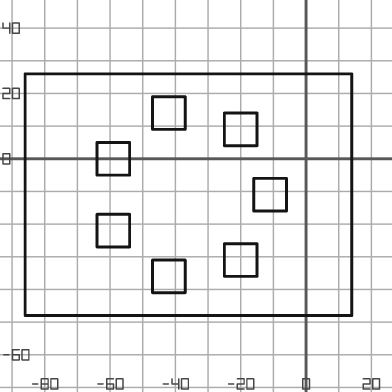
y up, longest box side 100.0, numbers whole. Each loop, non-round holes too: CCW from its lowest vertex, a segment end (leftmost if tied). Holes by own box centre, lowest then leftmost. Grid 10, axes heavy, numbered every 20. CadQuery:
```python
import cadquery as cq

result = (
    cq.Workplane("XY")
    .moveTo(-86.0, -48.0)
    .lineTo(14.0, -48.0)
    .lineTo(14.0, 26.0)
    .lineTo(-86.0, 26.0)
    .close()
    .moveTo(-47.0, -41.0)
    .lineTo(-37.0, -41.0)
    .lineTo(-37.0, -31.0)
    .lineTo(-47.0, -31.0)
    .close()
    .moveTo(-25.0, -36.0)
    .lineTo(-15.0, -36.0)
    .lineTo(-15.0, -26.0)
    .lineTo(-25.0, -26.0)
    .close()
    .moveTo(-64.0, -27.0)
    .lineTo(-54.0, -27.0)
    .lineTo(-54.0, -17.0)
    .lineTo(-64.0, -17.0)
    .close()
    .moveTo(-16.0, -16.0)
    .lineTo(-6.0, -16.0)
    .lineTo(-6.0, -6.0)
    .lineTo(-16.0, -6.0)
    .close()
    .moveTo(-64.0, -5.0)
    .lineTo(-54.0, -5.0)
    .lineTo(-54.0, 5.0)
    .lineTo(-64.0, 5.0)
    .close()
    .moveTo(-25.0, 4.0)
    .lineTo(-15.0, 4.0)
    .lineTo(-15.0, 14.0)
    .lineTo(-25.0, 14.0)
    .close()
    .moveTo(-47.0, 9.0)
    .lineTo(-37.0, 9.0)
    .lineTo(-37.0, 19.0)
    .lineTo(-47.0, 19.0)
    .close()
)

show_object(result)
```